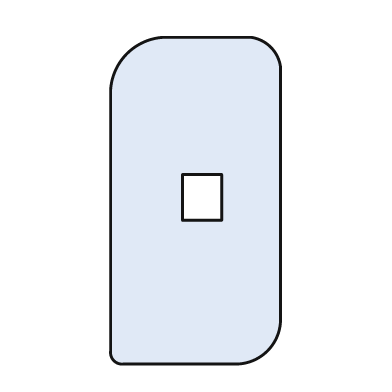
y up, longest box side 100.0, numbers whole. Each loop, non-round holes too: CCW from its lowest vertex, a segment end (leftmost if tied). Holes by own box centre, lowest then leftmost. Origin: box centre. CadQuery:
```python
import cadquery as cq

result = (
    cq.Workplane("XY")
    .moveTo(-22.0, -50.0)
    .lineTo(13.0, -50.0)
    .threePointArc((22.0, -46.0), (26.0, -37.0))
    .lineTo(26.0, 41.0)
    .threePointArc((23.0, 47.0), (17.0, 50.0))
    .lineTo(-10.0, 50.0)
    .threePointArc((-21.0, 45.0), (-26.0, 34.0))
    .lineTo(-26.0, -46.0)
    .threePointArc((-25.0, -49.0), (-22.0, -50.0))
    .close()
    .moveTo(-4.0, -6.0)
    .lineTo(8.0, -6.0)
    .lineTo(8.0, 8.0)
    .lineTo(-4.0, 8.0)
    .close()
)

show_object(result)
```